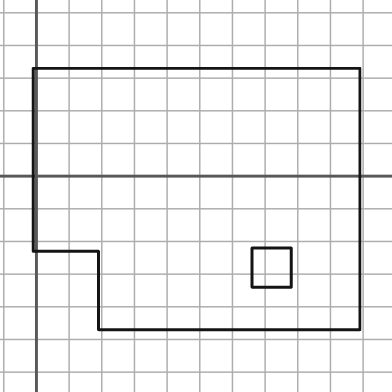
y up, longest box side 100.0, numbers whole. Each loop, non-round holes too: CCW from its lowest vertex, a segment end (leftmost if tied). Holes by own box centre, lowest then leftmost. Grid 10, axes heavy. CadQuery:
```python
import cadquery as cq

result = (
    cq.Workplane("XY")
    .moveTo(19.0, -47.0)
    .lineTo(99.0, -47.0)
    .lineTo(99.0, 33.0)
    .lineTo(-1.0, 33.0)
    .lineTo(-1.0, -23.0)
    .lineTo(19.0, -23.0)
    .close()
    .moveTo(66.0, -34.0)
    .lineTo(78.0, -34.0)
    .lineTo(78.0, -22.0)
    .lineTo(66.0, -22.0)
    .close()
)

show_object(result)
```